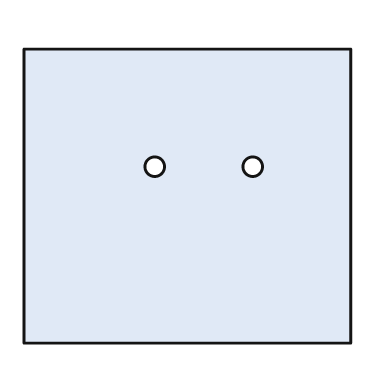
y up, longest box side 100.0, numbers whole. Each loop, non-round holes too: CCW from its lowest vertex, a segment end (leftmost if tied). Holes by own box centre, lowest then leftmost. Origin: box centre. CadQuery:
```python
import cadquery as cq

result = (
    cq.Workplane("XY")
    .moveTo(-50.0, -45.0)
    .lineTo(50.0, -45.0)
    .lineTo(50.0, 45.0)
    .lineTo(-50.0, 45.0)
    .close()
    .moveTo(-10.0, 9.0)
    .circle(3.0)
    .moveTo(20.0, 9.0)
    .circle(3.0)
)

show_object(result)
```